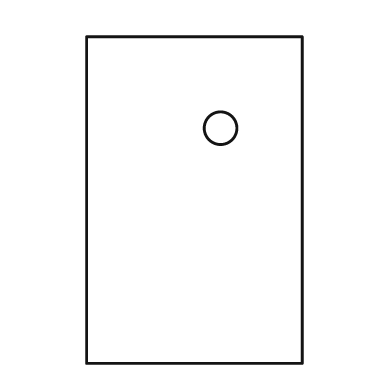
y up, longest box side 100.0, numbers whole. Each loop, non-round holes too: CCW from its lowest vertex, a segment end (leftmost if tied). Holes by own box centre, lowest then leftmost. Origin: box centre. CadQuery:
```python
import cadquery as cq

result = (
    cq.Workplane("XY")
    .moveTo(-33.0, -50.0)
    .lineTo(33.0, -50.0)
    .lineTo(33.0, 50.0)
    .lineTo(-33.0, 50.0)
    .close()
    .moveTo(8.0, 22.0)
    .circle(5.0)
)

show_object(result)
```